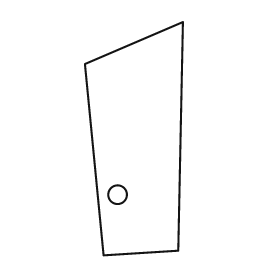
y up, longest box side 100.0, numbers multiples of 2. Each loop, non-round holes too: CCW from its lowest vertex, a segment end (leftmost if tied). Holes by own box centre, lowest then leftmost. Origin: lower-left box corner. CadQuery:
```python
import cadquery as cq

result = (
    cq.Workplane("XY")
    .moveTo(8.0, 0.0)
    .lineTo(40.0, 2.0)
    .lineTo(42.0, 100.0)
    .lineTo(0.0, 82.0)
    .close()
    .moveTo(14.0, 26.0)
    .circle(4.0)
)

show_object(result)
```